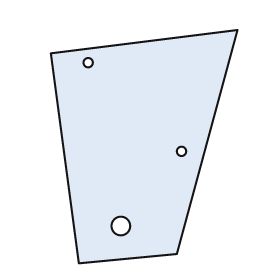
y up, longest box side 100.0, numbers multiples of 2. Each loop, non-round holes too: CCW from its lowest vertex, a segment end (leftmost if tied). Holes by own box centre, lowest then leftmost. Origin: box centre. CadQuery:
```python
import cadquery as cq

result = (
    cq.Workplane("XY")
    .moveTo(-28.0, -50.0)
    .lineTo(14.0, -46.0)
    .lineTo(40.0, 50.0)
    .lineTo(-40.0, 40.0)
    .close()
    .moveTo(-10.0, -34.0)
    .circle(4.0)
    .moveTo(16.0, -2.0)
    .circle(2.0)
    .moveTo(-24.0, 36.0)
    .circle(2.0)
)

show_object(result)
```